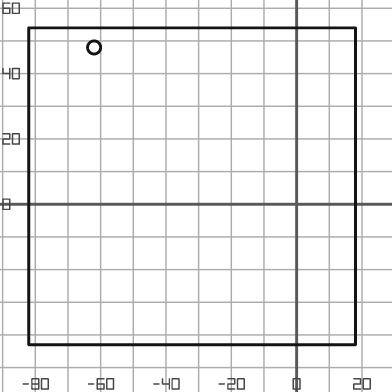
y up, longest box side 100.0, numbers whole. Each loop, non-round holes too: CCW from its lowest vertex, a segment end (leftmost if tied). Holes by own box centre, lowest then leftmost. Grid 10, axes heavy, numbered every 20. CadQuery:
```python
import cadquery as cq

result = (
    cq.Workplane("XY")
    .moveTo(-82.0, -43.0)
    .lineTo(18.0, -43.0)
    .lineTo(18.0, 54.0)
    .lineTo(-82.0, 54.0)
    .close()
    .moveTo(-62.0, 48.0)
    .circle(2.0)
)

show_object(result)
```